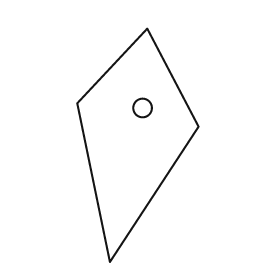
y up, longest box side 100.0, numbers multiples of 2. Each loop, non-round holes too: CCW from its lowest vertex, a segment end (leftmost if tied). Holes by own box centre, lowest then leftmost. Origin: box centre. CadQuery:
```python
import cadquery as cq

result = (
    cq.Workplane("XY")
    .moveTo(-12.0, -50.0)
    .lineTo(26.0, 8.0)
    .lineTo(4.0, 50.0)
    .lineTo(-26.0, 18.0)
    .close()
    .moveTo(2.0, 16.0)
    .circle(4.0)
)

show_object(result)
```